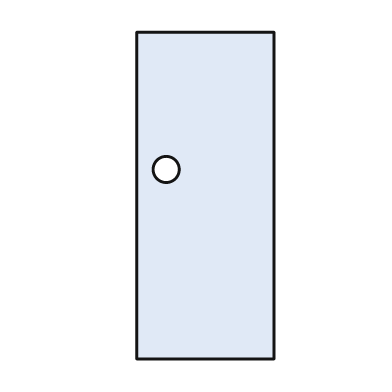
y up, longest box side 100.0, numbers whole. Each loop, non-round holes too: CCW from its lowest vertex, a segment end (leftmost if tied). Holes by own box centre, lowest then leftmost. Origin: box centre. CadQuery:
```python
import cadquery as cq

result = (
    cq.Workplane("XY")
    .moveTo(-21.0, -50.0)
    .lineTo(21.0, -50.0)
    .lineTo(21.0, 50.0)
    .lineTo(-21.0, 50.0)
    .close()
    .moveTo(-12.0, 8.0)
    .circle(4.0)
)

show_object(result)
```